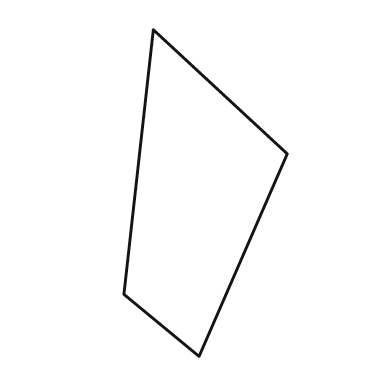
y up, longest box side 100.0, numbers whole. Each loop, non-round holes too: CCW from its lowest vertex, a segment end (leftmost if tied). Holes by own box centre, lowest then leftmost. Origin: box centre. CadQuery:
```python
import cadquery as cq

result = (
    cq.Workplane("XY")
    .moveTo(-2.0, -50.0)
    .lineTo(25.0, 12.0)
    .lineTo(-16.0, 50.0)
    .lineTo(-25.0, -31.0)
    .close()
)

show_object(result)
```